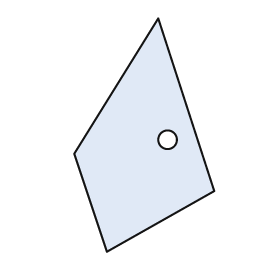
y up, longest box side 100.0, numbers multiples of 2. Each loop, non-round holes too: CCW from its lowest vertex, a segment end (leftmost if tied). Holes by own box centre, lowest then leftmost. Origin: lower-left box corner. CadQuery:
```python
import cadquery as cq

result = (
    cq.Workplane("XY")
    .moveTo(14.0, 0.0)
    .lineTo(60.0, 26.0)
    .lineTo(36.0, 100.0)
    .lineTo(0.0, 42.0)
    .close()
    .moveTo(40.0, 48.0)
    .circle(4.0)
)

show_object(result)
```